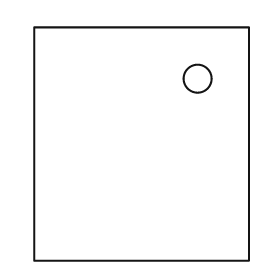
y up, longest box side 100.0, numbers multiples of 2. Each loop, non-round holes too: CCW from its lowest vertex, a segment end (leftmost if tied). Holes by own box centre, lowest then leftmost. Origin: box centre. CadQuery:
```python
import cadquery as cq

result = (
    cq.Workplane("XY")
    .moveTo(-46.0, -50.0)
    .lineTo(46.0, -50.0)
    .lineTo(46.0, 50.0)
    .lineTo(-46.0, 50.0)
    .close()
    .moveTo(24.0, 28.0)
    .circle(6.0)
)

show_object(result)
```